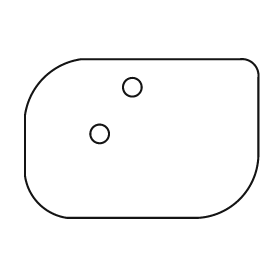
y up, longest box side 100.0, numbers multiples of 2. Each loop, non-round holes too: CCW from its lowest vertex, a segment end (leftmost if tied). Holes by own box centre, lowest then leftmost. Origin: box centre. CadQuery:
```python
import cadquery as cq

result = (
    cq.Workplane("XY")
    .moveTo(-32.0, -34.0)
    .lineTo(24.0, -34.0)
    .threePointArc((42.0, -26.0), (50.0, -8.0))
    .lineTo(50.0, 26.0)
    .threePointArc((48.0, 32.0), (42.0, 34.0))
    .lineTo(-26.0, 34.0)
    .threePointArc((-42.0, 26.0), (-50.0, 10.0))
    .lineTo(-50.0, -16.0)
    .threePointArc((-44.0, -28.0), (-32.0, -34.0))
    .close()
    .moveTo(-18.0, 2.0)
    .circle(4.0)
    .moveTo(-4.0, 22.0)
    .circle(4.0)
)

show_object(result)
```